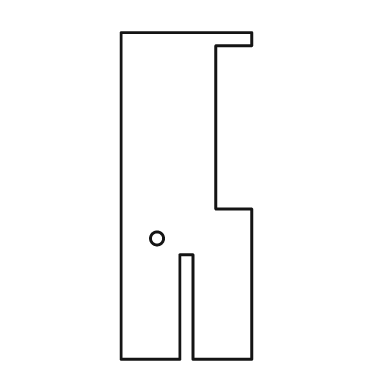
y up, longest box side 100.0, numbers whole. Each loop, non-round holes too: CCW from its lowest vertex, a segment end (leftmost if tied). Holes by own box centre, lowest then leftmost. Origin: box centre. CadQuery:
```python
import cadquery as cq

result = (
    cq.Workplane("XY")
    .moveTo(-20.0, -50.0)
    .lineTo(-2.0, -50.0)
    .lineTo(-2.0, -18.0)
    .lineTo(2.0, -18.0)
    .lineTo(2.0, -50.0)
    .lineTo(20.0, -50.0)
    .lineTo(20.0, -4.0)
    .lineTo(9.0, -4.0)
    .lineTo(9.0, 46.0)
    .lineTo(20.0, 46.0)
    .lineTo(20.0, 50.0)
    .lineTo(-20.0, 50.0)
    .close()
    .moveTo(-9.0, -13.0)
    .circle(2.0)
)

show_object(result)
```